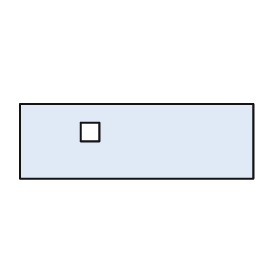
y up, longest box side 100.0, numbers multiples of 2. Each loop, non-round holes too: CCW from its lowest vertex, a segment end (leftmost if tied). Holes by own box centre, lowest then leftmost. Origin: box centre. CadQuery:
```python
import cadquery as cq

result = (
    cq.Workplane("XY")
    .moveTo(-50.0, -16.0)
    .lineTo(50.0, -16.0)
    .lineTo(50.0, 16.0)
    .lineTo(-50.0, 16.0)
    .close()
    .moveTo(-24.0, 0.0)
    .lineTo(-16.0, 0.0)
    .lineTo(-16.0, 8.0)
    .lineTo(-24.0, 8.0)
    .close()
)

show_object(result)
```